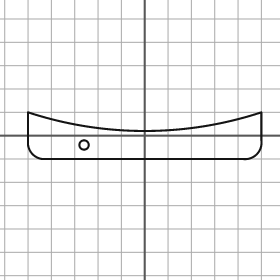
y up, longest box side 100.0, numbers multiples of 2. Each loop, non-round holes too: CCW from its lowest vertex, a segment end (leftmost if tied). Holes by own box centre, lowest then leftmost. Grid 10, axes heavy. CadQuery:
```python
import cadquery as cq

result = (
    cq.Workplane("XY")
    .moveTo(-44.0, -10.0)
    .lineTo(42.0, -10.0)
    .threePointArc((48.0, -8.0), (50.0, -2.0))
    .lineTo(50.0, 10.0)
    .threePointArc((0.0, 2.0), (-50.0, 10.0))
    .lineTo(-50.0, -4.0)
    .threePointArc((-48.0, -8.0), (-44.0, -10.0))
    .close()
    .moveTo(-26.0, -4.0)
    .circle(2.0)
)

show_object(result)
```